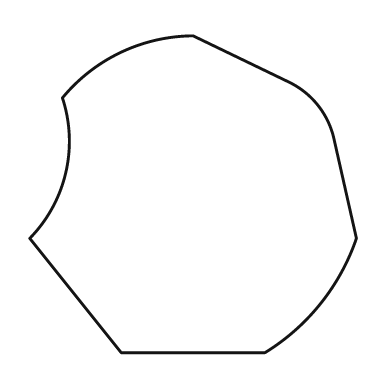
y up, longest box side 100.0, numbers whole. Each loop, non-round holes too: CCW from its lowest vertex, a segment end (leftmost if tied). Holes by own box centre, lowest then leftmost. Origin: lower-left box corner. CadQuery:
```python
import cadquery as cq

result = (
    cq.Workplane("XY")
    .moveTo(28.0, 0.0)
    .lineTo(72.0, 0.0)
    .threePointArc((89.0, 15.0), (100.0, 35.0))
    .lineTo(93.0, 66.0)
    .threePointArc((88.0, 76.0), (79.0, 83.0))
    .lineTo(50.0, 97.0)
    .threePointArc((28.0, 92.0), (10.0, 78.0))
    .threePointArc((11.0, 55.0), (0.0, 35.0))
    .close()
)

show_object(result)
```